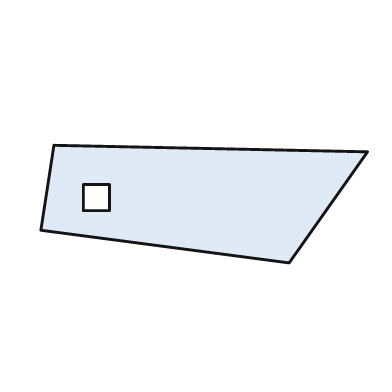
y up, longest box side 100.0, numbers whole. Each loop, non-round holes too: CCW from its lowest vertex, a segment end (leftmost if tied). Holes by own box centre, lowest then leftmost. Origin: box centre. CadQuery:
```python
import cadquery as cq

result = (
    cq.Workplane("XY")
    .moveTo(26.0, -18.0)
    .lineTo(50.0, 16.0)
    .lineTo(-46.0, 18.0)
    .lineTo(-50.0, -8.0)
    .close()
    .moveTo(-37.0, -2.0)
    .lineTo(-29.0, -2.0)
    .lineTo(-29.0, 6.0)
    .lineTo(-37.0, 6.0)
    .close()
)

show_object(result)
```